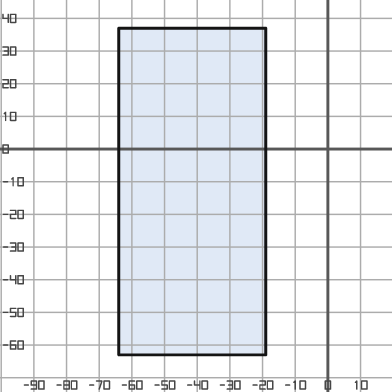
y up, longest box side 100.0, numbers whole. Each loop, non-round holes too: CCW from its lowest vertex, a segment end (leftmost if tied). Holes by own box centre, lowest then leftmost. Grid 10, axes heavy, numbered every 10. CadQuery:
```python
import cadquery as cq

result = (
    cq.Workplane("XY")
    .moveTo(-64.0, -63.0)
    .lineTo(-19.0, -63.0)
    .lineTo(-19.0, 37.0)
    .lineTo(-64.0, 37.0)
    .close()
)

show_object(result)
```